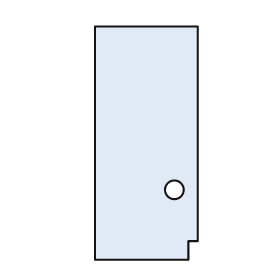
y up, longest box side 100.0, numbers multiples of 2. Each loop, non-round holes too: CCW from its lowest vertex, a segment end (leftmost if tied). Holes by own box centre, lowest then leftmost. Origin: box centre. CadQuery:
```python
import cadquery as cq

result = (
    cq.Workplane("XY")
    .moveTo(-22.0, -50.0)
    .lineTo(18.0, -50.0)
    .lineTo(18.0, -42.0)
    .lineTo(22.0, -42.0)
    .lineTo(22.0, 50.0)
    .lineTo(-22.0, 50.0)
    .close()
    .moveTo(12.0, -20.0)
    .circle(4.0)
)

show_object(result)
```